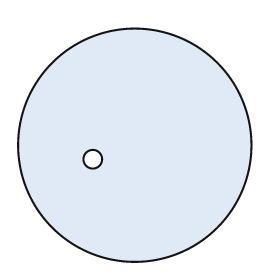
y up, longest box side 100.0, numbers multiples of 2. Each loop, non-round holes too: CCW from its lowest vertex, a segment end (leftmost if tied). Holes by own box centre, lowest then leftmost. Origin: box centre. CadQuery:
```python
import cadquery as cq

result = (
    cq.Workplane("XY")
    .moveTo(0.0, 0.0)
    .circle(50.0)
    .moveTo(-18.0, -6.0)
    .circle(4.0)
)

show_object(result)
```